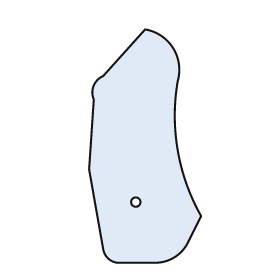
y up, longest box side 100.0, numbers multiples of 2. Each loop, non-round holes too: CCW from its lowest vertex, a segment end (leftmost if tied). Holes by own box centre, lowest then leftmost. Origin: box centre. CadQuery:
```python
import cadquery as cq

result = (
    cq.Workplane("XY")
    .moveTo(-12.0, -50.0)
    .lineTo(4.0, -50.0)
    .threePointArc((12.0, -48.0), (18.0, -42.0))
    .lineTo(24.0, -30.0)
    .threePointArc((14.0, -2.0), (14.0, 28.0))
    .threePointArc((12.0, 42.0), (0.0, 50.0))
    .lineTo(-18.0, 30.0)
    .threePointArc((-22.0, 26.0), (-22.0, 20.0))
    .lineTo(-24.0, -10.0)
    .lineTo(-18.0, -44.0)
    .threePointArc((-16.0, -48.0), (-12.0, -50.0))
    .close()
    .moveTo(-4.0, -24.0)
    .circle(2.0)
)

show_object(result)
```